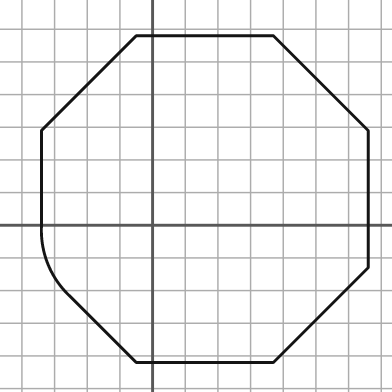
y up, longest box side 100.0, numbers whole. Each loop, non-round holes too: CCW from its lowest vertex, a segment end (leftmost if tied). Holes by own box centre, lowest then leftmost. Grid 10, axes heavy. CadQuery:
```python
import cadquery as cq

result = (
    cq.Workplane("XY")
    .moveTo(-5.0, -42.0)
    .lineTo(37.0, -42.0)
    .lineTo(66.0, -13.0)
    .lineTo(66.0, 29.0)
    .lineTo(37.0, 58.0)
    .lineTo(-5.0, 58.0)
    .lineTo(-34.0, 29.0)
    .lineTo(-34.0, 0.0)
    .threePointArc((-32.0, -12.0), (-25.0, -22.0))
    .close()
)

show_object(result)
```